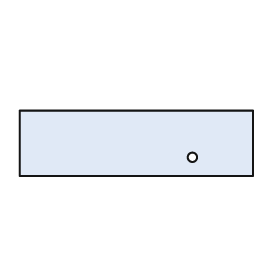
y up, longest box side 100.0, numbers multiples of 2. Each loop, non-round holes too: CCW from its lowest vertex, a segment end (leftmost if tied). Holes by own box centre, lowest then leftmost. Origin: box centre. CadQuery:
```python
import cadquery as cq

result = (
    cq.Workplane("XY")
    .moveTo(-50.0, -14.0)
    .lineTo(50.0, -14.0)
    .lineTo(50.0, 14.0)
    .lineTo(-50.0, 14.0)
    .close()
    .moveTo(24.0, -6.0)
    .circle(2.0)
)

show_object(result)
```